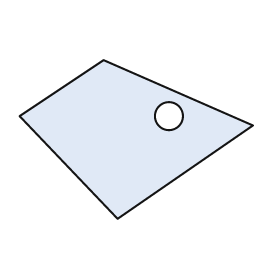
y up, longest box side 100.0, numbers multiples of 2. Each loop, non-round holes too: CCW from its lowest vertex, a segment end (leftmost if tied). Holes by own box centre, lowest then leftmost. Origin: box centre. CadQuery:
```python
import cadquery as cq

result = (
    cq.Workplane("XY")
    .moveTo(-8.0, -34.0)
    .lineTo(50.0, 6.0)
    .lineTo(-14.0, 34.0)
    .lineTo(-50.0, 10.0)
    .close()
    .moveTo(14.0, 10.0)
    .circle(6.0)
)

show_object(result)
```